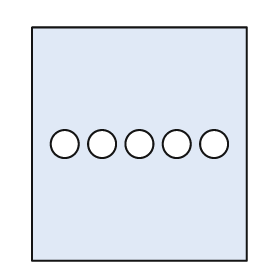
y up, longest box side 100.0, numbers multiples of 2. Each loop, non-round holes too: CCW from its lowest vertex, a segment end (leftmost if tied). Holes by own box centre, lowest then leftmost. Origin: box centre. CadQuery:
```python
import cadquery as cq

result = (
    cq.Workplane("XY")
    .moveTo(-46.0, -50.0)
    .lineTo(46.0, -50.0)
    .lineTo(46.0, 50.0)
    .lineTo(-46.0, 50.0)
    .close()
    .moveTo(-32.0, 0.0)
    .circle(6.0)
    .moveTo(-16.0, 0.0)
    .circle(6.0)
    .moveTo(0.0, 0.0)
    .circle(6.0)
    .moveTo(16.0, 0.0)
    .circle(6.0)
    .moveTo(32.0, 0.0)
    .circle(6.0)
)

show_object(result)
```